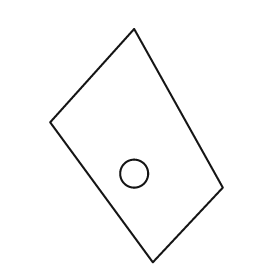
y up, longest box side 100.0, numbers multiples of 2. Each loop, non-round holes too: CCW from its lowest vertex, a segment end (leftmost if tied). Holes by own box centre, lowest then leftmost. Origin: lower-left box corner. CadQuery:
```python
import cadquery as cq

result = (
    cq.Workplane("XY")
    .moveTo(44.0, 0.0)
    .lineTo(74.0, 32.0)
    .lineTo(36.0, 100.0)
    .lineTo(0.0, 60.0)
    .close()
    .moveTo(36.0, 38.0)
    .circle(6.0)
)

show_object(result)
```